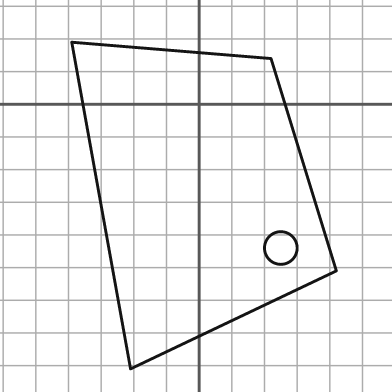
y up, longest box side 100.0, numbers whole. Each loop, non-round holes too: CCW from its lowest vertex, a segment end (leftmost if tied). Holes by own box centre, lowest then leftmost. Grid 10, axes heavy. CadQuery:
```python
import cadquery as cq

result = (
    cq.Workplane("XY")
    .moveTo(-21.0, -81.0)
    .lineTo(42.0, -51.0)
    .lineTo(22.0, 14.0)
    .lineTo(-39.0, 19.0)
    .close()
    .moveTo(25.0, -44.0)
    .circle(5.0)
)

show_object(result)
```